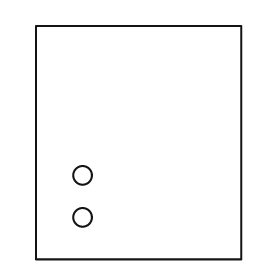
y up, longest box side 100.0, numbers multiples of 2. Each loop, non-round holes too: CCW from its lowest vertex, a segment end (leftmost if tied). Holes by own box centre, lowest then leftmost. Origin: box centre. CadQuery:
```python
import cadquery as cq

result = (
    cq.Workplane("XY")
    .moveTo(-44.0, -50.0)
    .lineTo(44.0, -50.0)
    .lineTo(44.0, 50.0)
    .lineTo(-44.0, 50.0)
    .close()
    .moveTo(-24.0, -32.0)
    .circle(4.0)
    .moveTo(-24.0, -14.0)
    .circle(4.0)
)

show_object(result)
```